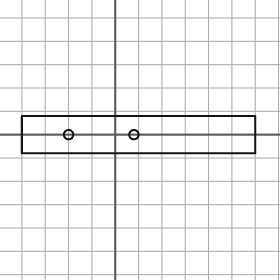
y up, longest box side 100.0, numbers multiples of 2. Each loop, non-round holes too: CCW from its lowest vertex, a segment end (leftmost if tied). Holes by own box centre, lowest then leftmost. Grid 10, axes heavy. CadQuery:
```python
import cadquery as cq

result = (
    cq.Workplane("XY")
    .moveTo(-40.0, -8.0)
    .lineTo(60.0, -8.0)
    .lineTo(60.0, 8.0)
    .lineTo(-40.0, 8.0)
    .close()
    .moveTo(-20.0, 0.0)
    .circle(2.0)
    .moveTo(8.0, 0.0)
    .circle(2.0)
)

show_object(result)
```